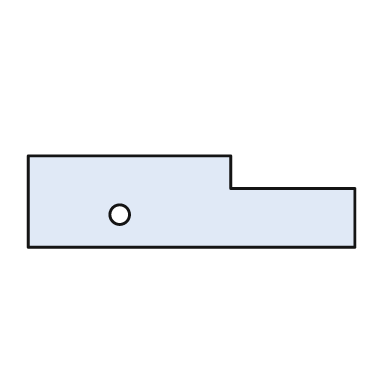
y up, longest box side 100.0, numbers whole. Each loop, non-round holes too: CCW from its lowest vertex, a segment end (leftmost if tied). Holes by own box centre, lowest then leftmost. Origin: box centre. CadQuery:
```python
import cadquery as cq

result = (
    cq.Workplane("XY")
    .moveTo(-50.0, -14.0)
    .lineTo(50.0, -14.0)
    .lineTo(50.0, 4.0)
    .lineTo(12.0, 4.0)
    .lineTo(12.0, 14.0)
    .lineTo(-50.0, 14.0)
    .close()
    .moveTo(-22.0, -4.0)
    .circle(3.0)
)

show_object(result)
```